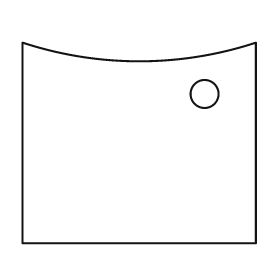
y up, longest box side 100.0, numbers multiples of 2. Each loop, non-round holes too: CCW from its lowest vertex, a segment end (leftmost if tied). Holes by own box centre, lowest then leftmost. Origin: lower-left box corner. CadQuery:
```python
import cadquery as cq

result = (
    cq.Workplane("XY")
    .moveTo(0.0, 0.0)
    .lineTo(100.0, 0.0)
    .lineTo(100.0, 86.0)
    .threePointArc((50.0, 78.0), (0.0, 86.0))
    .close()
    .moveTo(78.0, 64.0)
    .circle(6.0)
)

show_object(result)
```